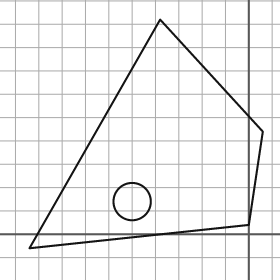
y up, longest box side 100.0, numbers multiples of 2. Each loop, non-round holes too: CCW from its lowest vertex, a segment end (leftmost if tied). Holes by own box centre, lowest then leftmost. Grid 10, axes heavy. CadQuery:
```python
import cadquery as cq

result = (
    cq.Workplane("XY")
    .moveTo(-94.0, -6.0)
    .lineTo(0.0, 4.0)
    .lineTo(6.0, 44.0)
    .lineTo(-38.0, 92.0)
    .close()
    .moveTo(-50.0, 14.0)
    .circle(8.0)
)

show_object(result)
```